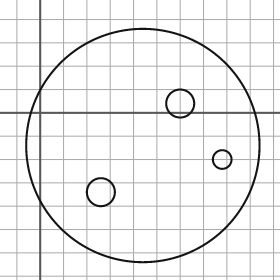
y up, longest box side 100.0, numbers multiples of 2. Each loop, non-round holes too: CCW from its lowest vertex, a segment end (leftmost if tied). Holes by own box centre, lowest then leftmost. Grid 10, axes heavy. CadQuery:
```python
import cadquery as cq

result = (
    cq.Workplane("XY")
    .moveTo(44.0, -14.0)
    .circle(50.0)
    .moveTo(26.0, -34.0)
    .circle(6.0)
    .moveTo(78.0, -20.0)
    .circle(4.0)
    .moveTo(60.0, 4.0)
    .circle(6.0)
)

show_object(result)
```